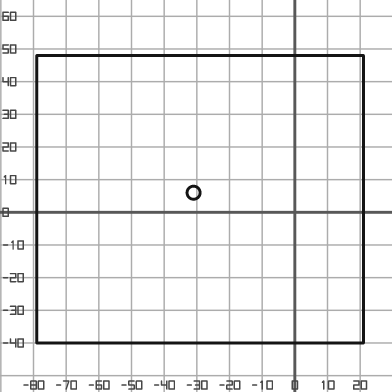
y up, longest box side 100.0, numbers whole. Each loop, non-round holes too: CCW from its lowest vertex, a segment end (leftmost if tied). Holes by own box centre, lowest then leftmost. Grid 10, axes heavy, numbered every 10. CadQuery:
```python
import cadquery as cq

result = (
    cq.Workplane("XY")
    .moveTo(-79.0, -40.0)
    .lineTo(21.0, -40.0)
    .lineTo(21.0, 48.0)
    .lineTo(-79.0, 48.0)
    .close()
    .moveTo(-31.0, 6.0)
    .circle(2.0)
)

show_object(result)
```